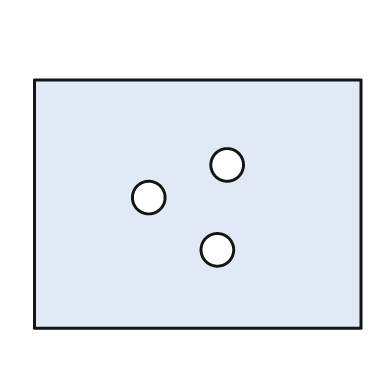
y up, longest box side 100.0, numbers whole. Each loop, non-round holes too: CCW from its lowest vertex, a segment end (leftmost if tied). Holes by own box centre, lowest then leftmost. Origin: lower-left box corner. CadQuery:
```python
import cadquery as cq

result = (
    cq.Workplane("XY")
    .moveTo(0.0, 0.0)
    .lineTo(100.0, 0.0)
    .lineTo(100.0, 76.0)
    .lineTo(0.0, 76.0)
    .close()
    .moveTo(56.0, 24.0)
    .circle(5.0)
    .moveTo(35.0, 40.0)
    .circle(5.0)
    .moveTo(59.0, 50.0)
    .circle(5.0)
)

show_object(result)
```